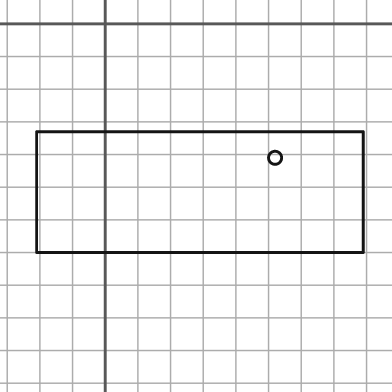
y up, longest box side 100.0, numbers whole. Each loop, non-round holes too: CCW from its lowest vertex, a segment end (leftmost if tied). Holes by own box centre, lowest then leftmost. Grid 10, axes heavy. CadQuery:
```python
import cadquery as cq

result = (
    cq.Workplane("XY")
    .moveTo(-21.0, -70.0)
    .lineTo(79.0, -70.0)
    .lineTo(79.0, -33.0)
    .lineTo(-21.0, -33.0)
    .close()
    .moveTo(52.0, -41.0)
    .circle(2.0)
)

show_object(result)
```